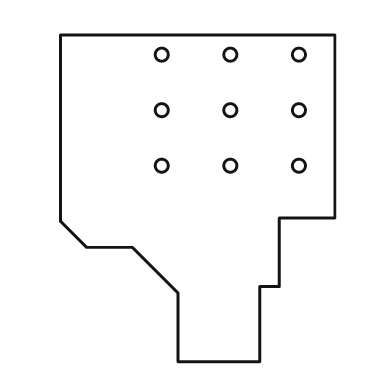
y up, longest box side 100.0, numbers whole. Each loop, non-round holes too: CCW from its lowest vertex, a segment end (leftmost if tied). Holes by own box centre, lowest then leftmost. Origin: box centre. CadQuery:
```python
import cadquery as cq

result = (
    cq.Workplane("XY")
    .moveTo(-6.0, -50.0)
    .lineTo(19.0, -50.0)
    .lineTo(19.0, -27.0)
    .lineTo(25.0, -27.0)
    .lineTo(25.0, -6.0)
    .lineTo(42.0, -6.0)
    .lineTo(42.0, 50.0)
    .lineTo(-42.0, 50.0)
    .lineTo(-42.0, -7.0)
    .lineTo(-34.0, -15.0)
    .lineTo(-20.0, -15.0)
    .lineTo(-6.0, -29.0)
    .close()
    .moveTo(-11.0, 10.0)
    .circle(2.0)
    .moveTo(10.0, 10.0)
    .circle(2.0)
    .moveTo(31.0, 10.0)
    .circle(2.0)
    .moveTo(-11.0, 27.0)
    .circle(2.0)
    .moveTo(10.0, 27.0)
    .circle(2.0)
    .moveTo(31.0, 27.0)
    .circle(2.0)
    .moveTo(-11.0, 44.0)
    .circle(2.0)
    .moveTo(10.0, 44.0)
    .circle(2.0)
    .moveTo(31.0, 44.0)
    .circle(2.0)
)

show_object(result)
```